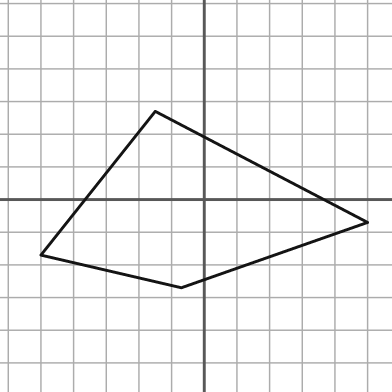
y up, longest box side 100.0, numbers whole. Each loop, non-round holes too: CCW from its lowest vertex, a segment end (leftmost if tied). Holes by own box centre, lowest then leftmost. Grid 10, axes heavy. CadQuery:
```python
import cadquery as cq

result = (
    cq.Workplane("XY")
    .moveTo(-7.0, -27.0)
    .lineTo(50.0, -7.0)
    .lineTo(-15.0, 27.0)
    .lineTo(-50.0, -17.0)
    .close()
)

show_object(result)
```